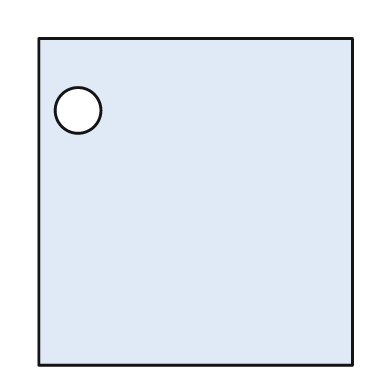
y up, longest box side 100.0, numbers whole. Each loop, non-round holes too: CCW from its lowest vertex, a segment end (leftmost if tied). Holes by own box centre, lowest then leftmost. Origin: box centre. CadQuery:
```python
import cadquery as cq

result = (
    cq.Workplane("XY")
    .moveTo(-48.0, -50.0)
    .lineTo(48.0, -50.0)
    .lineTo(48.0, 50.0)
    .lineTo(-48.0, 50.0)
    .close()
    .moveTo(-36.0, 28.0)
    .circle(7.0)
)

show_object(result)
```